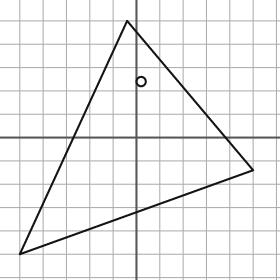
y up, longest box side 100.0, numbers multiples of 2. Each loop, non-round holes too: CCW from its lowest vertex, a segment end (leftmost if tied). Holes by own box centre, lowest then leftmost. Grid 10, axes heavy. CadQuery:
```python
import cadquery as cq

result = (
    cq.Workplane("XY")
    .moveTo(-50.0, -50.0)
    .lineTo(50.0, -14.0)
    .lineTo(-4.0, 50.0)
    .close()
    .moveTo(2.0, 24.0)
    .circle(2.0)
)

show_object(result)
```